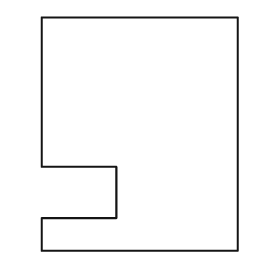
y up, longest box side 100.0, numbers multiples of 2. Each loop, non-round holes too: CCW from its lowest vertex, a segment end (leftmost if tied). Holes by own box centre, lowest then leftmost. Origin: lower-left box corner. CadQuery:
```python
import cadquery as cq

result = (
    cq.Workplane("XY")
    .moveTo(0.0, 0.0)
    .lineTo(84.0, 0.0)
    .lineTo(84.0, 100.0)
    .lineTo(0.0, 100.0)
    .lineTo(0.0, 36.0)
    .lineTo(32.0, 36.0)
    .lineTo(32.0, 14.0)
    .lineTo(0.0, 14.0)
    .close()
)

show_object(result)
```